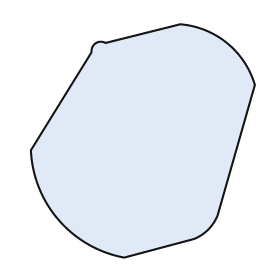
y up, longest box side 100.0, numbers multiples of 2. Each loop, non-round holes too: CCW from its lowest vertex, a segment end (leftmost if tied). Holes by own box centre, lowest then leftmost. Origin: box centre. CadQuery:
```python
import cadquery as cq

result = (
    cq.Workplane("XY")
    .moveTo(-8.0, -50.0)
    .lineTo(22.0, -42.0)
    .threePointArc((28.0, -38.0), (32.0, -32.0))
    .lineTo(48.0, 24.0)
    .threePointArc((36.0, 42.0), (16.0, 50.0))
    .lineTo(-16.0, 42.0)
    .threePointArc((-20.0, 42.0), (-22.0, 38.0))
    .lineTo(-48.0, -4.0)
    .threePointArc((-36.0, -34.0), (-8.0, -50.0))
    .close()
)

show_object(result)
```